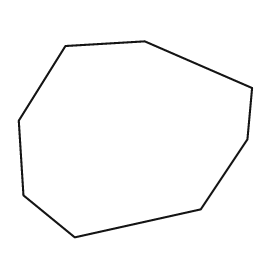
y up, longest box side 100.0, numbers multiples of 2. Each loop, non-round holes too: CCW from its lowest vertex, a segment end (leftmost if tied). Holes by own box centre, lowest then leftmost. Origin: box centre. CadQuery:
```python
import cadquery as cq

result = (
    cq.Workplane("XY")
    .moveTo(-26.0, -42.0)
    .lineTo(28.0, -30.0)
    .lineTo(48.0, 0.0)
    .lineTo(50.0, 22.0)
    .lineTo(4.0, 42.0)
    .lineTo(-30.0, 40.0)
    .lineTo(-50.0, 8.0)
    .lineTo(-48.0, -24.0)
    .close()
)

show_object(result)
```